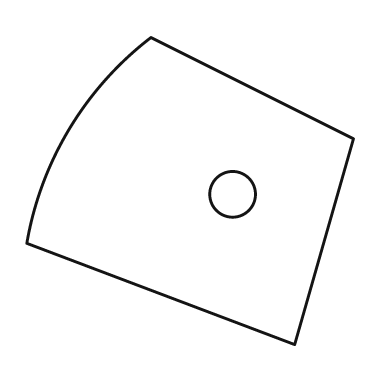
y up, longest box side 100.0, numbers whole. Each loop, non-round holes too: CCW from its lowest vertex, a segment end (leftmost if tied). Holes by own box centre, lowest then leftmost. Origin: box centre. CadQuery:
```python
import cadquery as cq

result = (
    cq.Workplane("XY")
    .moveTo(32.0, -47.0)
    .lineTo(50.0, 16.0)
    .lineTo(-12.0, 47.0)
    .threePointArc((-37.0, 19.0), (-50.0, -16.0))
    .close()
    .moveTo(13.0, -1.0)
    .circle(7.0)
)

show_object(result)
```